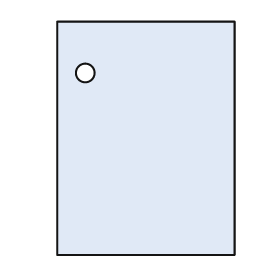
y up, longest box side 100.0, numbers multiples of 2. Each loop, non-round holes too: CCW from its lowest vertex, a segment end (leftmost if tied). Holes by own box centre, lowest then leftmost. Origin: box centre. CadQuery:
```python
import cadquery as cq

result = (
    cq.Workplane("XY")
    .moveTo(-38.0, -50.0)
    .lineTo(38.0, -50.0)
    .lineTo(38.0, 50.0)
    .lineTo(-38.0, 50.0)
    .close()
    .moveTo(-26.0, 28.0)
    .circle(4.0)
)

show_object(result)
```